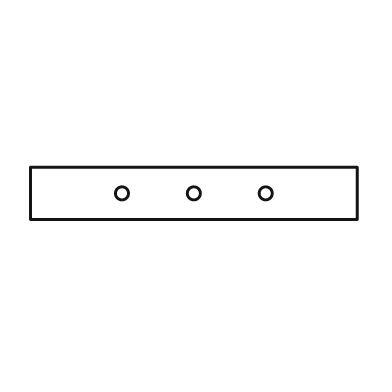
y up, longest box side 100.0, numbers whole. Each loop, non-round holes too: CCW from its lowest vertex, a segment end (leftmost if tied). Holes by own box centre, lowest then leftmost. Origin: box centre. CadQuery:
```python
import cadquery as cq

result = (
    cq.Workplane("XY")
    .moveTo(-50.0, -8.0)
    .lineTo(50.0, -8.0)
    .lineTo(50.0, 8.0)
    .lineTo(-50.0, 8.0)
    .close()
    .moveTo(-22.0, 0.0)
    .circle(2.0)
    .moveTo(0.0, 0.0)
    .circle(2.0)
    .moveTo(22.0, 0.0)
    .circle(2.0)
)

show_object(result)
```